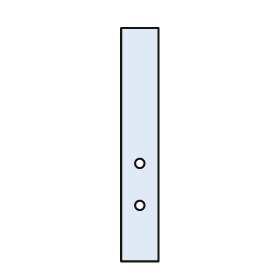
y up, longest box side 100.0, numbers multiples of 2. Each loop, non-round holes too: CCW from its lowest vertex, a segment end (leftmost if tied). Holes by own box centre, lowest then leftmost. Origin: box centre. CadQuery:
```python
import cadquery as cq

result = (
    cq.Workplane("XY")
    .moveTo(-8.0, -50.0)
    .lineTo(8.0, -50.0)
    .lineTo(8.0, 50.0)
    .lineTo(-8.0, 50.0)
    .close()
    .moveTo(0.0, -26.0)
    .circle(2.0)
    .moveTo(0.0, -8.0)
    .circle(2.0)
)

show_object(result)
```